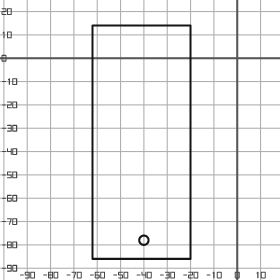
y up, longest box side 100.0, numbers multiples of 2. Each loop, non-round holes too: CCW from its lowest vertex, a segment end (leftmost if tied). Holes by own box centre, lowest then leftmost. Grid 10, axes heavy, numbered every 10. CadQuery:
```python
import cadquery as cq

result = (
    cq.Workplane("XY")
    .moveTo(-62.0, -86.0)
    .lineTo(-20.0, -86.0)
    .lineTo(-20.0, 14.0)
    .lineTo(-62.0, 14.0)
    .close()
    .moveTo(-40.0, -78.0)
    .circle(2.0)
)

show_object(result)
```